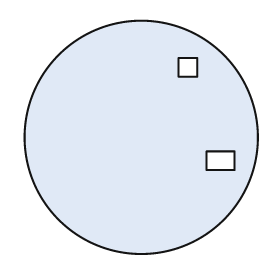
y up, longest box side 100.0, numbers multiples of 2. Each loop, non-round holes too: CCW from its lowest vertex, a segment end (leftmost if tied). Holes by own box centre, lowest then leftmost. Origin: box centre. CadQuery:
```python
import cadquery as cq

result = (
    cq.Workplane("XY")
    .moveTo(0.0, 0.0)
    .circle(50.0)
    .moveTo(28.0, -14.0)
    .lineTo(40.0, -14.0)
    .lineTo(40.0, -6.0)
    .lineTo(28.0, -6.0)
    .close()
    .moveTo(16.0, 26.0)
    .lineTo(24.0, 26.0)
    .lineTo(24.0, 34.0)
    .lineTo(16.0, 34.0)
    .close()
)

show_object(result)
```